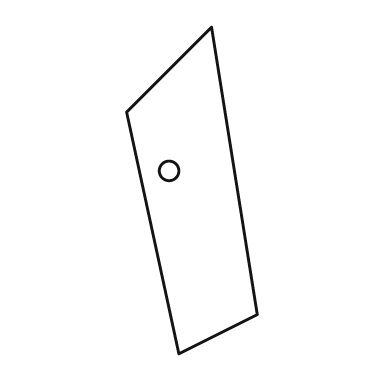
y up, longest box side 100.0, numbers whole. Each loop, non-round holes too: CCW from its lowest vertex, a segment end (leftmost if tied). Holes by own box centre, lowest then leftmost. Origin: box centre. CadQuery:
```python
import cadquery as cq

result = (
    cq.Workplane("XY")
    .moveTo(-4.0, -50.0)
    .lineTo(20.0, -38.0)
    .lineTo(6.0, 50.0)
    .lineTo(-20.0, 24.0)
    .close()
    .moveTo(-7.0, 6.0)
    .circle(3.0)
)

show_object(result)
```